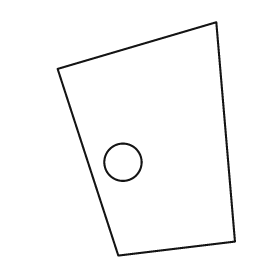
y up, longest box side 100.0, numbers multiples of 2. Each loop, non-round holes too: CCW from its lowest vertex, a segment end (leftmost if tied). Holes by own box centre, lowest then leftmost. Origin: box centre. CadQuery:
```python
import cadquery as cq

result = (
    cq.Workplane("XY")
    .moveTo(-12.0, -50.0)
    .lineTo(38.0, -44.0)
    .lineTo(30.0, 50.0)
    .lineTo(-38.0, 30.0)
    .close()
    .moveTo(-10.0, -10.0)
    .circle(8.0)
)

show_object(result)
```